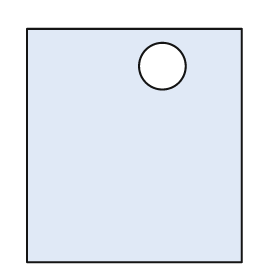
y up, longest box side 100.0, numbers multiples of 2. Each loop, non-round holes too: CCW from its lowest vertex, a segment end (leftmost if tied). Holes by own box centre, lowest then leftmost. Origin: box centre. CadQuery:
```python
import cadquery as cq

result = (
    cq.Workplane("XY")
    .moveTo(-46.0, -50.0)
    .lineTo(46.0, -50.0)
    .lineTo(46.0, 50.0)
    .lineTo(-46.0, 50.0)
    .close()
    .moveTo(12.0, 34.0)
    .circle(10.0)
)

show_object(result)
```